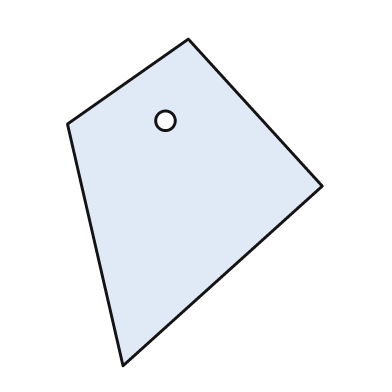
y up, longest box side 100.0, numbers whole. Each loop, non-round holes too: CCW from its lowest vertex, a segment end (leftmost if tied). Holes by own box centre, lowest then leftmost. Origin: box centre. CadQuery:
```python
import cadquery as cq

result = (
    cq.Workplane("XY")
    .moveTo(-22.0, -50.0)
    .lineTo(39.0, 5.0)
    .lineTo(-2.0, 50.0)
    .lineTo(-39.0, 24.0)
    .close()
    .moveTo(-9.0, 25.0)
    .circle(3.0)
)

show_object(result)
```